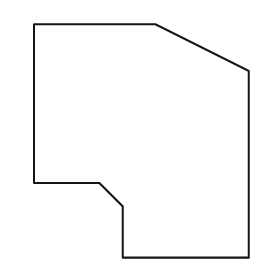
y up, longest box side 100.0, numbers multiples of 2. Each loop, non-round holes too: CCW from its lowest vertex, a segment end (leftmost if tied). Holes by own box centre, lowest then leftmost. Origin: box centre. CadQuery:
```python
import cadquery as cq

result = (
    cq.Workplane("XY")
    .moveTo(-8.0, -50.0)
    .lineTo(46.0, -50.0)
    .lineTo(46.0, 30.0)
    .lineTo(6.0, 50.0)
    .lineTo(-46.0, 50.0)
    .lineTo(-46.0, -18.0)
    .lineTo(-18.0, -18.0)
    .lineTo(-8.0, -28.0)
    .close()
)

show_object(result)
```